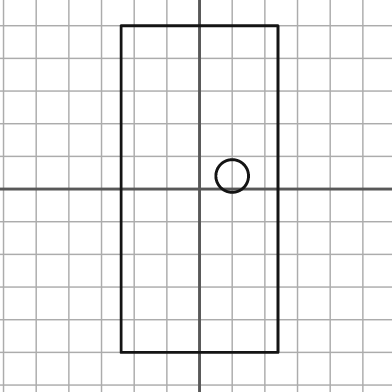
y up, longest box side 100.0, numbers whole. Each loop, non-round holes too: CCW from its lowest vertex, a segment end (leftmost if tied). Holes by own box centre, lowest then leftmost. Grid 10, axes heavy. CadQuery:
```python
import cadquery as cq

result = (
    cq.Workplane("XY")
    .moveTo(-24.0, -50.0)
    .lineTo(24.0, -50.0)
    .lineTo(24.0, 50.0)
    .lineTo(-24.0, 50.0)
    .close()
    .moveTo(10.0, 4.0)
    .circle(5.0)
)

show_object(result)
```